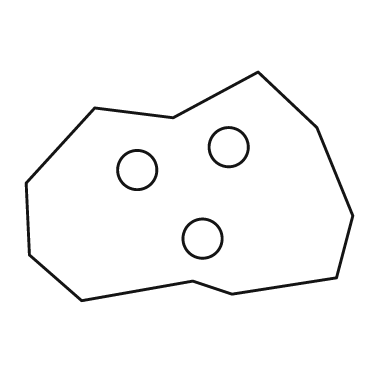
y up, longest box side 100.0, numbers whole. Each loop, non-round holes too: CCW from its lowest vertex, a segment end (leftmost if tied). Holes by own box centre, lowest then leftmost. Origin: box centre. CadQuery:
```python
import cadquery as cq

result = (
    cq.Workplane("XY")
    .moveTo(-33.0, -35.0)
    .lineTo(1.0, -29.0)
    .lineTo(13.0, -33.0)
    .lineTo(45.0, -28.0)
    .lineTo(50.0, -9.0)
    .lineTo(39.0, 18.0)
    .lineTo(21.0, 35.0)
    .lineTo(-5.0, 21.0)
    .lineTo(-29.0, 24.0)
    .lineTo(-50.0, 1.0)
    .lineTo(-49.0, -21.0)
    .close()
    .moveTo(4.0, -16.0)
    .circle(6.0)
    .moveTo(-16.0, 5.0)
    .circle(6.0)
    .moveTo(12.0, 12.0)
    .circle(6.0)
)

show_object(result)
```